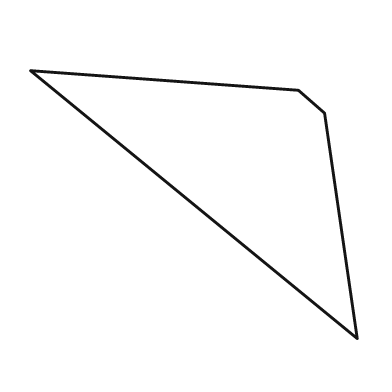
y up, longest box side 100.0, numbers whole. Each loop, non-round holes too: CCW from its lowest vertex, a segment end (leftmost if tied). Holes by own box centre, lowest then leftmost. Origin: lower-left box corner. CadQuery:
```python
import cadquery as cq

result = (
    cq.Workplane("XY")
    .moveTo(100.0, 0.0)
    .lineTo(90.0, 69.0)
    .lineTo(82.0, 76.0)
    .lineTo(0.0, 82.0)
    .close()
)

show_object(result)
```